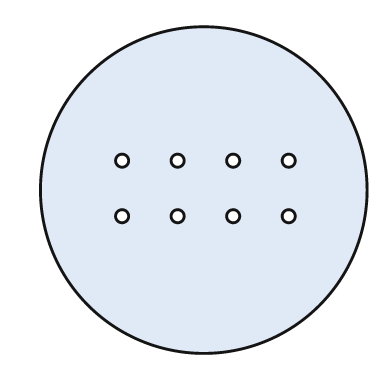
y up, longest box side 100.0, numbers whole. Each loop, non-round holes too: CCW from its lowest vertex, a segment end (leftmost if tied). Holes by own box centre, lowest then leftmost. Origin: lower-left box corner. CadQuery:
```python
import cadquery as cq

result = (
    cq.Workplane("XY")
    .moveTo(50.0, 50.0)
    .circle(50.0)
    .moveTo(25.0, 42.0)
    .circle(2.0)
    .moveTo(42.0, 42.0)
    .circle(2.0)
    .moveTo(59.0, 42.0)
    .circle(2.0)
    .moveTo(76.0, 42.0)
    .circle(2.0)
    .moveTo(25.0, 59.0)
    .circle(2.0)
    .moveTo(42.0, 59.0)
    .circle(2.0)
    .moveTo(59.0, 59.0)
    .circle(2.0)
    .moveTo(76.0, 59.0)
    .circle(2.0)
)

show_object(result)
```